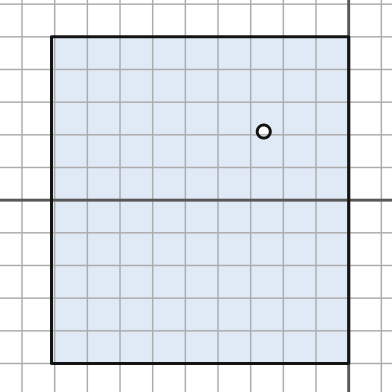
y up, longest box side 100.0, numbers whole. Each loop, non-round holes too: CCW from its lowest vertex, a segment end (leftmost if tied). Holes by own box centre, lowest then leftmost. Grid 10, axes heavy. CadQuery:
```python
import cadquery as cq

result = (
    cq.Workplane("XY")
    .moveTo(-91.0, -50.0)
    .lineTo(0.0, -50.0)
    .lineTo(0.0, 50.0)
    .lineTo(-91.0, 50.0)
    .close()
    .moveTo(-26.0, 21.0)
    .circle(2.0)
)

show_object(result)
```